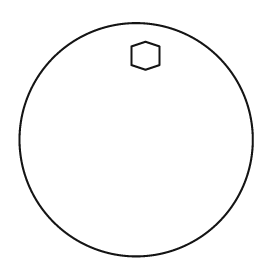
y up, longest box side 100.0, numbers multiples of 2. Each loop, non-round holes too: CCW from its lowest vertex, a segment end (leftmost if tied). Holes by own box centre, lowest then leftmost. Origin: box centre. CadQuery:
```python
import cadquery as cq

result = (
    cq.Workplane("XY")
    .moveTo(0.0, 0.0)
    .circle(50.0)
    .moveTo(4.0, 30.0)
    .lineTo(10.0, 32.0)
    .lineTo(10.0, 40.0)
    .lineTo(4.0, 42.0)
    .lineTo(-2.0, 40.0)
    .lineTo(-2.0, 32.0)
    .close()
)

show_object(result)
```